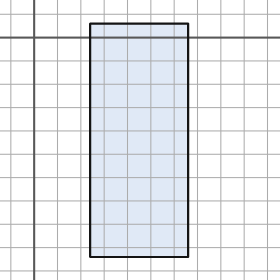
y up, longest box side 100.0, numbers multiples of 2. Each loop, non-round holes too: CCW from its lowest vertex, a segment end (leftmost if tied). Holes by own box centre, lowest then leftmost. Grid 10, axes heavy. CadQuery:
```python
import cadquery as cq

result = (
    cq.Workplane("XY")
    .moveTo(24.0, -94.0)
    .lineTo(66.0, -94.0)
    .lineTo(66.0, 6.0)
    .lineTo(24.0, 6.0)
    .close()
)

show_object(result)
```